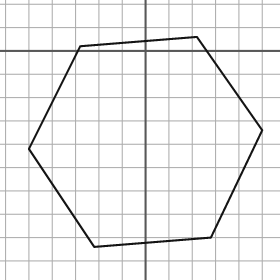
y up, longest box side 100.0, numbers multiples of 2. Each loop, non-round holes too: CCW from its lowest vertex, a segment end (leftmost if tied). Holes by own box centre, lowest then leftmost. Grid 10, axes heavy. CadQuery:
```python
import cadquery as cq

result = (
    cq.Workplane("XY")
    .moveTo(-22.0, -84.0)
    .lineTo(28.0, -80.0)
    .lineTo(50.0, -34.0)
    .lineTo(22.0, 6.0)
    .lineTo(-28.0, 2.0)
    .lineTo(-50.0, -42.0)
    .close()
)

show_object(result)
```